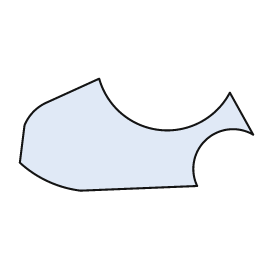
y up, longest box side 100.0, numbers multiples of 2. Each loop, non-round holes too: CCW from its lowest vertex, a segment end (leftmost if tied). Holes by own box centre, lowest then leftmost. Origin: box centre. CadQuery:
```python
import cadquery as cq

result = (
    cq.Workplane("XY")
    .moveTo(-24.0, -24.0)
    .lineTo(26.0, -22.0)
    .threePointArc((30.0, -2.0), (50.0, 0.0))
    .lineTo(40.0, 18.0)
    .threePointArc((10.0, 2.0), (-16.0, 24.0))
    .lineTo(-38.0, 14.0)
    .threePointArc((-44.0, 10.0), (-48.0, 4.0))
    .lineTo(-50.0, -12.0)
    .threePointArc((-38.0, -20.0), (-24.0, -24.0))
    .close()
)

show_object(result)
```